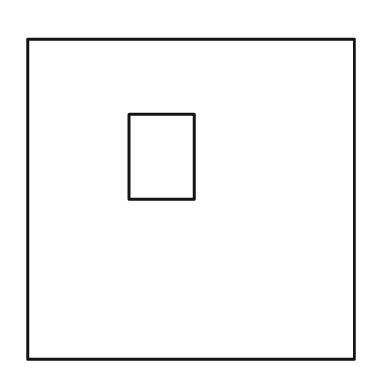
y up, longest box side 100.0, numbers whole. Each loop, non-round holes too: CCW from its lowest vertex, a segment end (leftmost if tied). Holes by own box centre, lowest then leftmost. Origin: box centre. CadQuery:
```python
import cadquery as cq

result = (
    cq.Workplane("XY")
    .moveTo(-50.0, -49.0)
    .lineTo(50.0, -49.0)
    .lineTo(50.0, 49.0)
    .lineTo(-50.0, 49.0)
    .close()
    .moveTo(-19.0, 0.0)
    .lineTo(1.0, 0.0)
    .lineTo(1.0, 26.0)
    .lineTo(-19.0, 26.0)
    .close()
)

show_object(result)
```